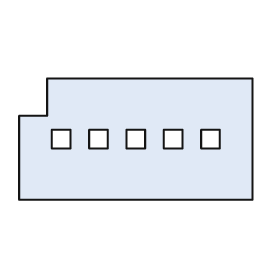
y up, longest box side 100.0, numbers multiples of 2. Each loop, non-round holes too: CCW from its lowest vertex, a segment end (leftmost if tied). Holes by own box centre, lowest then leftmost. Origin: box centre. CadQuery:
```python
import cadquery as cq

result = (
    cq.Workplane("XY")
    .moveTo(-50.0, -26.0)
    .lineTo(50.0, -26.0)
    .lineTo(50.0, 26.0)
    .lineTo(-38.0, 26.0)
    .lineTo(-38.0, 10.0)
    .lineTo(-50.0, 10.0)
    .close()
    .moveTo(-36.0, -4.0)
    .lineTo(-28.0, -4.0)
    .lineTo(-28.0, 4.0)
    .lineTo(-36.0, 4.0)
    .close()
    .moveTo(-20.0, -4.0)
    .lineTo(-12.0, -4.0)
    .lineTo(-12.0, 4.0)
    .lineTo(-20.0, 4.0)
    .close()
    .moveTo(-4.0, -4.0)
    .lineTo(4.0, -4.0)
    .lineTo(4.0, 4.0)
    .lineTo(-4.0, 4.0)
    .close()
    .moveTo(12.0, -4.0)
    .lineTo(20.0, -4.0)
    .lineTo(20.0, 4.0)
    .lineTo(12.0, 4.0)
    .close()
    .moveTo(28.0, -4.0)
    .lineTo(36.0, -4.0)
    .lineTo(36.0, 4.0)
    .lineTo(28.0, 4.0)
    .close()
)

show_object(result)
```